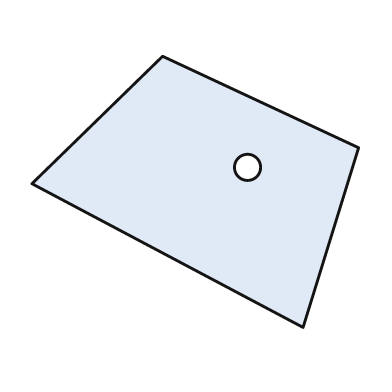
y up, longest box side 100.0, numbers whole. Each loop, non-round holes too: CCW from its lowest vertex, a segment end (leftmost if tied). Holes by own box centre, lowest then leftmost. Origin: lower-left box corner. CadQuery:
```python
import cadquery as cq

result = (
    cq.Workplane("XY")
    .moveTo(83.0, 0.0)
    .lineTo(100.0, 55.0)
    .lineTo(40.0, 83.0)
    .lineTo(0.0, 44.0)
    .close()
    .moveTo(66.0, 49.0)
    .circle(4.0)
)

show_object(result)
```